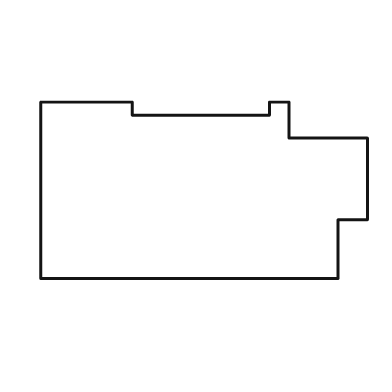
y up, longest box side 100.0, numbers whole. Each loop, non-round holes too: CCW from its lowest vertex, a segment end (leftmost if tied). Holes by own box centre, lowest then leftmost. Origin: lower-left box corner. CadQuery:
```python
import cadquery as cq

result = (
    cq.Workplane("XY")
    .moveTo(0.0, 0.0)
    .lineTo(91.0, 0.0)
    .lineTo(91.0, 18.0)
    .lineTo(100.0, 18.0)
    .lineTo(100.0, 43.0)
    .lineTo(76.0, 43.0)
    .lineTo(76.0, 54.0)
    .lineTo(70.0, 54.0)
    .lineTo(70.0, 50.0)
    .lineTo(28.0, 50.0)
    .lineTo(28.0, 54.0)
    .lineTo(0.0, 54.0)
    .close()
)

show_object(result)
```